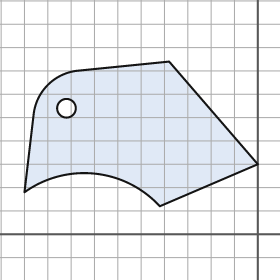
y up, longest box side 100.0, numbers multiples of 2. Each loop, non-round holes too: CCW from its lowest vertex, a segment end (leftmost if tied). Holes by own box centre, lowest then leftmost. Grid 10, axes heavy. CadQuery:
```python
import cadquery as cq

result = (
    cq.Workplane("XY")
    .moveTo(-42.0, 12.0)
    .lineTo(0.0, 30.0)
    .lineTo(-38.0, 74.0)
    .lineTo(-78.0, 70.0)
    .threePointArc((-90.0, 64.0), (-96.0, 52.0))
    .lineTo(-100.0, 18.0)
    .threePointArc((-70.0, 26.0), (-42.0, 12.0))
    .close()
    .moveTo(-82.0, 54.0)
    .circle(4.0)
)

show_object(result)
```